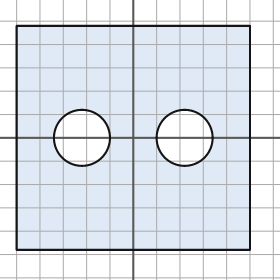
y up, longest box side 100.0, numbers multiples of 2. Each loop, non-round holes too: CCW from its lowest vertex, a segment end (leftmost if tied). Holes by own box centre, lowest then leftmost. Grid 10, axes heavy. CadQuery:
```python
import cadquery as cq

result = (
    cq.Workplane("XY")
    .moveTo(-50.0, -48.0)
    .lineTo(50.0, -48.0)
    .lineTo(50.0, 48.0)
    .lineTo(-50.0, 48.0)
    .close()
    .moveTo(-22.0, 0.0)
    .circle(12.0)
    .moveTo(22.0, 0.0)
    .circle(12.0)
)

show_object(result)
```